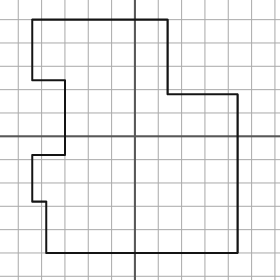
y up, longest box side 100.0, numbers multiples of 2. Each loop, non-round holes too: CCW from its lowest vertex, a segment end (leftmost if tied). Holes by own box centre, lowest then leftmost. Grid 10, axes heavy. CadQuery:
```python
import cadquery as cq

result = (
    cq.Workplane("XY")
    .moveTo(-38.0, -50.0)
    .lineTo(44.0, -50.0)
    .lineTo(44.0, 18.0)
    .lineTo(14.0, 18.0)
    .lineTo(14.0, 50.0)
    .lineTo(-44.0, 50.0)
    .lineTo(-44.0, 24.0)
    .lineTo(-30.0, 24.0)
    .lineTo(-30.0, -8.0)
    .lineTo(-44.0, -8.0)
    .lineTo(-44.0, -28.0)
    .lineTo(-38.0, -28.0)
    .close()
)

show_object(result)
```